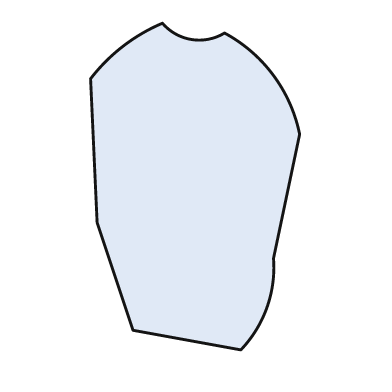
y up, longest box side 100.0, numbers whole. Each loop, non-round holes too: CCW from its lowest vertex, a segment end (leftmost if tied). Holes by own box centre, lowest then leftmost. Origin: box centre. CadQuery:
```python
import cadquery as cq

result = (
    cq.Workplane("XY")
    .moveTo(14.0, -50.0)
    .threePointArc((22.0, -37.0), (24.0, -22.0))
    .lineTo(32.0, 16.0)
    .threePointArc((24.0, 34.0), (9.0, 47.0))
    .threePointArc((-1.0, 45.0), (-10.0, 50.0))
    .threePointArc((-22.0, 43.0), (-32.0, 33.0))
    .lineTo(-30.0, -11.0)
    .lineTo(-19.0, -44.0)
    .close()
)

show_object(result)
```